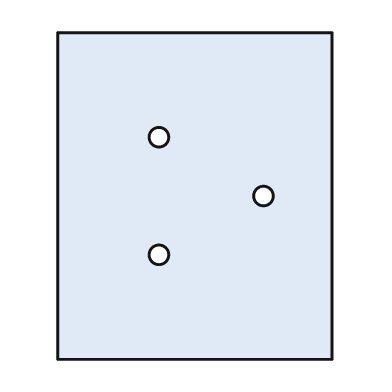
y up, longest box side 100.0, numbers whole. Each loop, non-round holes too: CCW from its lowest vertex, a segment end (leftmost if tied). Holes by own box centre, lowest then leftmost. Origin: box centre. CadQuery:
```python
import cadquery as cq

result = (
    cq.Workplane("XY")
    .moveTo(-42.0, -50.0)
    .lineTo(42.0, -50.0)
    .lineTo(42.0, 50.0)
    .lineTo(-42.0, 50.0)
    .close()
    .moveTo(-11.0, -18.0)
    .circle(3.0)
    .moveTo(21.0, 0.0)
    .circle(3.0)
    .moveTo(-11.0, 18.0)
    .circle(3.0)
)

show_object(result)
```